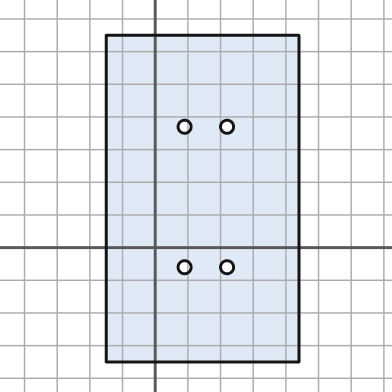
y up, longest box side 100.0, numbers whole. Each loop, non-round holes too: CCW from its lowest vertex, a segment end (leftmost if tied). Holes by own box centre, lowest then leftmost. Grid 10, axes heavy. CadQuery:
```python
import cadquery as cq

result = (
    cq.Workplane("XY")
    .moveTo(-15.0, -35.0)
    .lineTo(44.0, -35.0)
    .lineTo(44.0, 65.0)
    .lineTo(-15.0, 65.0)
    .close()
    .moveTo(9.0, -6.0)
    .circle(2.0)
    .moveTo(22.0, -6.0)
    .circle(2.0)
    .moveTo(9.0, 37.0)
    .circle(2.0)
    .moveTo(22.0, 37.0)
    .circle(2.0)
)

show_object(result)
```